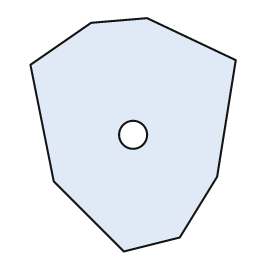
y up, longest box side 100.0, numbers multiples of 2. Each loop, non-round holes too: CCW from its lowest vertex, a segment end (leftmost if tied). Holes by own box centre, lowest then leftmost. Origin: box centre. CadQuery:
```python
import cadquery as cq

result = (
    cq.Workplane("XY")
    .moveTo(-4.0, -50.0)
    .lineTo(20.0, -44.0)
    .lineTo(36.0, -18.0)
    .lineTo(44.0, 32.0)
    .lineTo(6.0, 50.0)
    .lineTo(-18.0, 48.0)
    .lineTo(-44.0, 30.0)
    .lineTo(-34.0, -20.0)
    .close()
    .moveTo(0.0, 0.0)
    .circle(6.0)
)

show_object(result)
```